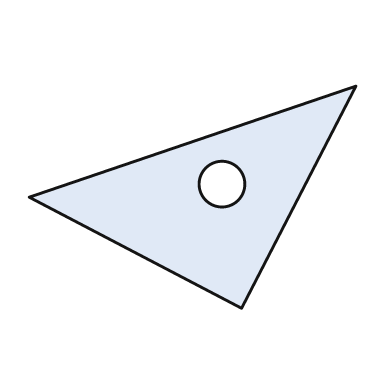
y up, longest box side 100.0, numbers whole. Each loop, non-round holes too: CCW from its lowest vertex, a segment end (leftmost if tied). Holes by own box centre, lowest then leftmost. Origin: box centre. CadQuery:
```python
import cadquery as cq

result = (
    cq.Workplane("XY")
    .moveTo(15.0, -34.0)
    .lineTo(50.0, 34.0)
    .lineTo(-50.0, 0.0)
    .close()
    .moveTo(9.0, 4.0)
    .circle(7.0)
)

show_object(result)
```